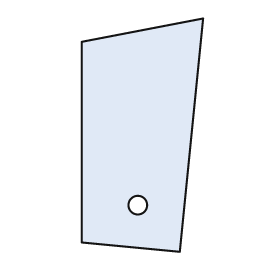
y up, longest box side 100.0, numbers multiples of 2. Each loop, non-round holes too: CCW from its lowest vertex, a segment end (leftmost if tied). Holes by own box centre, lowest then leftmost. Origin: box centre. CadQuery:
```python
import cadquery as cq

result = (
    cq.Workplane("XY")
    .moveTo(16.0, -50.0)
    .lineTo(26.0, 50.0)
    .lineTo(-26.0, 40.0)
    .lineTo(-26.0, -46.0)
    .close()
    .moveTo(-2.0, -30.0)
    .circle(4.0)
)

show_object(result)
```